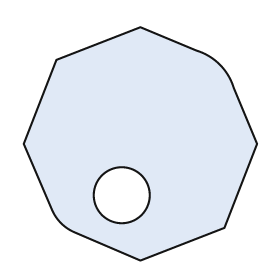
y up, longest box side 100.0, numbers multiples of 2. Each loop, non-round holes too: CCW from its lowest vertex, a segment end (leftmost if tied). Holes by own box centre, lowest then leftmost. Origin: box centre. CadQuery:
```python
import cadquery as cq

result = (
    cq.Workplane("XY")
    .moveTo(0.0, -50.0)
    .lineTo(36.0, -36.0)
    .lineTo(50.0, 0.0)
    .lineTo(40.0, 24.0)
    .threePointArc((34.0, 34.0), (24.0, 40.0))
    .lineTo(0.0, 50.0)
    .lineTo(-36.0, 36.0)
    .lineTo(-50.0, 0.0)
    .lineTo(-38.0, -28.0)
    .threePointArc((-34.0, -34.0), (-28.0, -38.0))
    .close()
    .moveTo(-8.0, -22.0)
    .circle(12.0)
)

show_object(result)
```